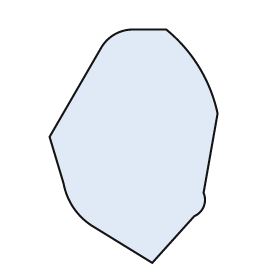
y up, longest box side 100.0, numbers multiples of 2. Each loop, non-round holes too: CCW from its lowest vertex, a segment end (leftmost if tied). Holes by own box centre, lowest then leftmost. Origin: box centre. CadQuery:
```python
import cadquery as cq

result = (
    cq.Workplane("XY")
    .moveTo(8.0, -50.0)
    .lineTo(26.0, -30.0)
    .threePointArc((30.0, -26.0), (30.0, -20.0))
    .lineTo(36.0, 14.0)
    .threePointArc((28.0, 34.0), (14.0, 50.0))
    .lineTo(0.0, 50.0)
    .threePointArc((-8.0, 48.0), (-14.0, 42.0))
    .lineTo(-36.0, 4.0)
    .lineTo(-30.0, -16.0)
    .threePointArc((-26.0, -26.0), (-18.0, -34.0))
    .close()
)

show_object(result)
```